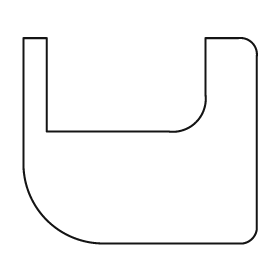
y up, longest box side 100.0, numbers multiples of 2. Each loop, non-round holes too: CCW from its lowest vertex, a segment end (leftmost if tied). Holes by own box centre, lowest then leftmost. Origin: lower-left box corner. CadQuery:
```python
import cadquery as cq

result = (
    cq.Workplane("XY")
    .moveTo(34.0, 0.0)
    .lineTo(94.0, 0.0)
    .threePointArc((98.0, 2.0), (100.0, 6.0))
    .lineTo(100.0, 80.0)
    .threePointArc((98.0, 86.0), (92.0, 88.0))
    .lineTo(78.0, 88.0)
    .lineTo(78.0, 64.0)
    .threePointArc((74.0, 52.0), (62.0, 48.0))
    .lineTo(10.0, 48.0)
    .lineTo(10.0, 88.0)
    .lineTo(0.0, 88.0)
    .lineTo(0.0, 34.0)
    .threePointArc((10.0, 10.0), (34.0, 0.0))
    .close()
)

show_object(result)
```